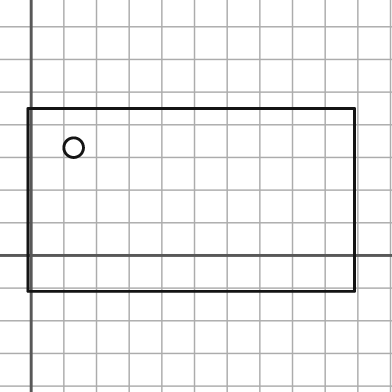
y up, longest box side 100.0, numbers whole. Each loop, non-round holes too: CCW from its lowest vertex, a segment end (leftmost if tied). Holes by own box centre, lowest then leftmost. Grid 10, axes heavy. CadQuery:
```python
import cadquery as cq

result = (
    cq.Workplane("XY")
    .moveTo(-1.0, -11.0)
    .lineTo(99.0, -11.0)
    .lineTo(99.0, 45.0)
    .lineTo(-1.0, 45.0)
    .close()
    .moveTo(13.0, 33.0)
    .circle(3.0)
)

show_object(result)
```